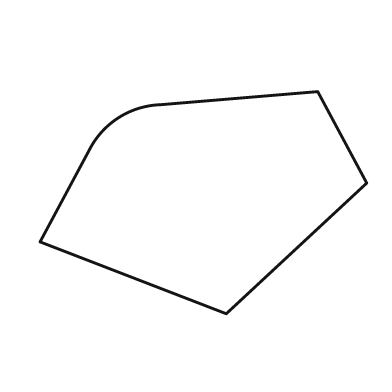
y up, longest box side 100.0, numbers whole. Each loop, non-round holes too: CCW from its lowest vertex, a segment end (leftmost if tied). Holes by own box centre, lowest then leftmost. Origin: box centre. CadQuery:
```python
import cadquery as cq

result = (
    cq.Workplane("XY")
    .moveTo(7.0, -34.0)
    .lineTo(50.0, 6.0)
    .lineTo(35.0, 34.0)
    .lineTo(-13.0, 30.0)
    .threePointArc((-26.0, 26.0), (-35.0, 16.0))
    .lineTo(-50.0, -12.0)
    .close()
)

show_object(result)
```